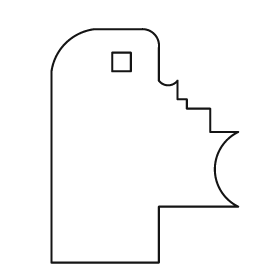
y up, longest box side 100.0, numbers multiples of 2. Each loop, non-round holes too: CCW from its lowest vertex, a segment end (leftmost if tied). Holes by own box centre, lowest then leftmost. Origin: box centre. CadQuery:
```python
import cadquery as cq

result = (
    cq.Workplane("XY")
    .moveTo(-40.0, -50.0)
    .lineTo(6.0, -50.0)
    .lineTo(6.0, -26.0)
    .lineTo(40.0, -26.0)
    .threePointArc((30.0, -10.0), (40.0, 6.0))
    .lineTo(28.0, 6.0)
    .lineTo(28.0, 16.0)
    .lineTo(18.0, 16.0)
    .lineTo(18.0, 20.0)
    .lineTo(14.0, 20.0)
    .lineTo(14.0, 28.0)
    .threePointArc((10.0, 26.0), (6.0, 28.0))
    .lineTo(6.0, 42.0)
    .threePointArc((4.0, 48.0), (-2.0, 50.0))
    .lineTo(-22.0, 50.0)
    .threePointArc((-34.0, 44.0), (-40.0, 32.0))
    .close()
    .moveTo(-14.0, 32.0)
    .lineTo(-6.0, 32.0)
    .lineTo(-6.0, 40.0)
    .lineTo(-14.0, 40.0)
    .close()
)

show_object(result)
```